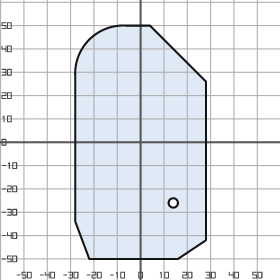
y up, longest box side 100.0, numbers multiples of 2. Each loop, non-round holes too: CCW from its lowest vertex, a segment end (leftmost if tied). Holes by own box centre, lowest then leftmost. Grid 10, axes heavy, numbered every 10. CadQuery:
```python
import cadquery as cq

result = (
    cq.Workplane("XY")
    .moveTo(-22.0, -50.0)
    .lineTo(16.0, -50.0)
    .lineTo(28.0, -42.0)
    .lineTo(28.0, 26.0)
    .lineTo(4.0, 50.0)
    .lineTo(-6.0, 50.0)
    .threePointArc((-22.0, 44.0), (-28.0, 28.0))
    .lineTo(-28.0, -34.0)
    .close()
    .moveTo(14.0, -26.0)
    .circle(2.0)
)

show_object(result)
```